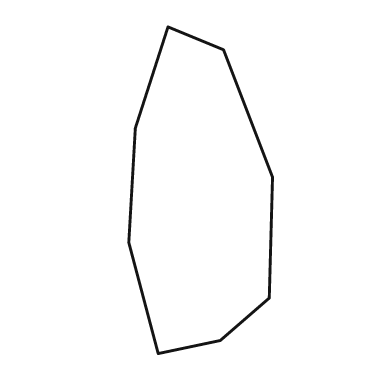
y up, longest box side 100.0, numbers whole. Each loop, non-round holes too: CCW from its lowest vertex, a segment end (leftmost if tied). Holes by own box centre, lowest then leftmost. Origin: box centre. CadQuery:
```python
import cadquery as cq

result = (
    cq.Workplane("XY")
    .moveTo(-13.0, -50.0)
    .lineTo(6.0, -46.0)
    .lineTo(21.0, -33.0)
    .lineTo(22.0, 4.0)
    .lineTo(7.0, 43.0)
    .lineTo(-10.0, 50.0)
    .lineTo(-20.0, 19.0)
    .lineTo(-22.0, -16.0)
    .close()
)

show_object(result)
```